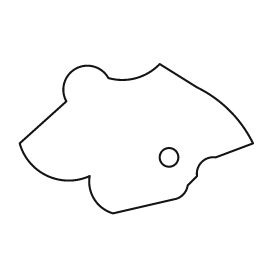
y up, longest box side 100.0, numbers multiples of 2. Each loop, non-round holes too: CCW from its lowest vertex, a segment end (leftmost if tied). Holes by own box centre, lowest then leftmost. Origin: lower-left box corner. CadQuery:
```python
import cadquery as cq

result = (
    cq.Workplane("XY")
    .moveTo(40.0, 0.0)
    .lineTo(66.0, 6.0)
    .threePointArc((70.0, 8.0), (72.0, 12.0))
    .lineTo(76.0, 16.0)
    .threePointArc((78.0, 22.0), (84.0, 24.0))
    .lineTo(100.0, 30.0)
    .threePointArc((90.0, 44.0), (76.0, 54.0))
    .lineTo(60.0, 64.0)
    .threePointArc((50.0, 58.0), (38.0, 58.0))
    .threePointArc((24.0, 62.0), (20.0, 48.0))
    .lineTo(0.0, 30.0)
    .threePointArc((12.0, 16.0), (30.0, 16.0))
    .threePointArc((32.0, 6.0), (40.0, 0.0))
    .close()
    .moveTo(64.0, 24.0)
    .circle(4.0)
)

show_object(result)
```